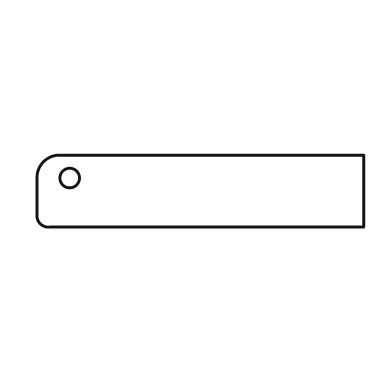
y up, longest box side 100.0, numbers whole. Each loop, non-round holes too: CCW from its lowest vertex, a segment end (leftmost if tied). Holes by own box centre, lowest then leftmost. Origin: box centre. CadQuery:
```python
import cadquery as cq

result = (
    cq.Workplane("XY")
    .moveTo(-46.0, -11.0)
    .lineTo(50.0, -11.0)
    .lineTo(50.0, 11.0)
    .lineTo(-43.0, 11.0)
    .threePointArc((-48.0, 9.0), (-50.0, 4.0))
    .lineTo(-50.0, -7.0)
    .threePointArc((-49.0, -10.0), (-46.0, -11.0))
    .close()
    .moveTo(-40.0, 4.0)
    .circle(3.0)
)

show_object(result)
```